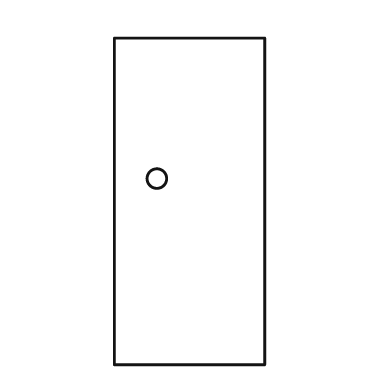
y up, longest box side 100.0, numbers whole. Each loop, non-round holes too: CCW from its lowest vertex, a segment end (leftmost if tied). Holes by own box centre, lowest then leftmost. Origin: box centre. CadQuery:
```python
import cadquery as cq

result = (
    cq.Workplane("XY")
    .moveTo(-23.0, -50.0)
    .lineTo(23.0, -50.0)
    .lineTo(23.0, 50.0)
    .lineTo(-23.0, 50.0)
    .close()
    .moveTo(-10.0, 7.0)
    .circle(3.0)
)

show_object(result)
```